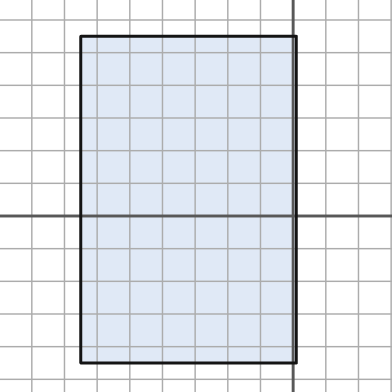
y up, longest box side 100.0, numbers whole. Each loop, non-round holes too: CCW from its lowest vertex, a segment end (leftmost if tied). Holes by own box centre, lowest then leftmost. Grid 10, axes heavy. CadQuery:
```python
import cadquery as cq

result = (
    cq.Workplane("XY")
    .moveTo(-65.0, -45.0)
    .lineTo(1.0, -45.0)
    .lineTo(1.0, 55.0)
    .lineTo(-65.0, 55.0)
    .close()
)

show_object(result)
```